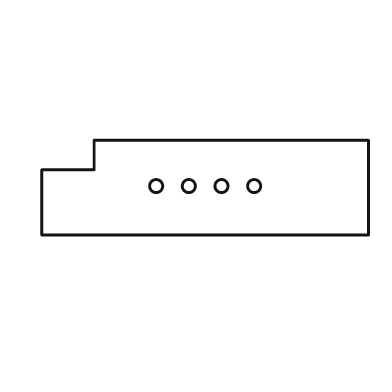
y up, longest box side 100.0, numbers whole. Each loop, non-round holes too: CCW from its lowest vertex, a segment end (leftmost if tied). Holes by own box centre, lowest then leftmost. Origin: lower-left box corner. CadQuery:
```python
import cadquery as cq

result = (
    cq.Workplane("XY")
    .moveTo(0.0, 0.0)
    .lineTo(100.0, 0.0)
    .lineTo(100.0, 29.0)
    .lineTo(16.0, 29.0)
    .lineTo(16.0, 20.0)
    .lineTo(0.0, 20.0)
    .close()
    .moveTo(35.0, 15.0)
    .circle(2.0)
    .moveTo(45.0, 15.0)
    .circle(2.0)
    .moveTo(55.0, 15.0)
    .circle(2.0)
    .moveTo(65.0, 15.0)
    .circle(2.0)
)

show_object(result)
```